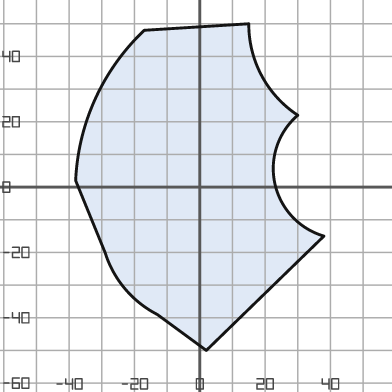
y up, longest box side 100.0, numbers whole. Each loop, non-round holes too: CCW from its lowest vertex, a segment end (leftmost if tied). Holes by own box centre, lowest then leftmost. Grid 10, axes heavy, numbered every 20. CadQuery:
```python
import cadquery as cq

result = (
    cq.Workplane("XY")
    .moveTo(2.0, -50.0)
    .lineTo(38.0, -15.0)
    .threePointArc((23.0, 1.0), (30.0, 22.0))
    .threePointArc((19.0, 34.0), (15.0, 50.0))
    .lineTo(-17.0, 48.0)
    .threePointArc((-32.0, 27.0), (-38.0, 2.0))
    .lineTo(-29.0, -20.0)
    .threePointArc((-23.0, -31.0), (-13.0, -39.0))
    .close()
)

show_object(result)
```